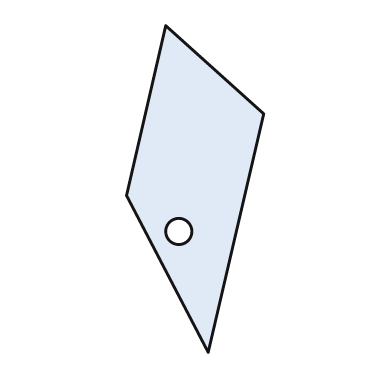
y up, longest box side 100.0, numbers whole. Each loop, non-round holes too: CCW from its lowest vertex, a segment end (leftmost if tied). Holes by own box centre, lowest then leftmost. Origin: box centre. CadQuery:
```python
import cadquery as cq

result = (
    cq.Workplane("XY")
    .moveTo(4.0, -50.0)
    .lineTo(21.0, 23.0)
    .lineTo(-9.0, 50.0)
    .lineTo(-21.0, -2.0)
    .close()
    .moveTo(-5.0, -13.0)
    .circle(4.0)
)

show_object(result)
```